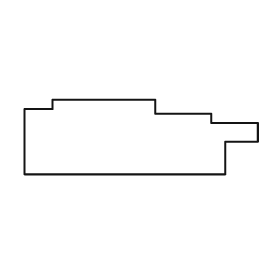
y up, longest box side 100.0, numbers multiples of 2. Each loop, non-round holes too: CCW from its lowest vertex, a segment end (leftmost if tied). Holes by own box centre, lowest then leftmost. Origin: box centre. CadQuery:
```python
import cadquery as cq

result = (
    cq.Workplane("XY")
    .moveTo(-50.0, -16.0)
    .lineTo(36.0, -16.0)
    .lineTo(36.0, -2.0)
    .lineTo(50.0, -2.0)
    .lineTo(50.0, 6.0)
    .lineTo(30.0, 6.0)
    .lineTo(30.0, 10.0)
    .lineTo(6.0, 10.0)
    .lineTo(6.0, 16.0)
    .lineTo(-38.0, 16.0)
    .lineTo(-38.0, 12.0)
    .lineTo(-50.0, 12.0)
    .close()
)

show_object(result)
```